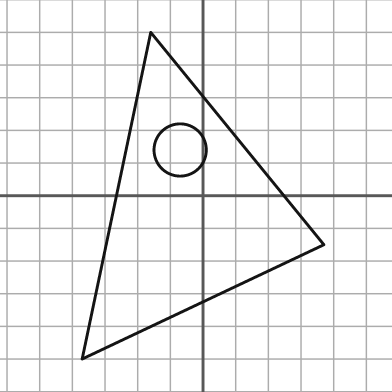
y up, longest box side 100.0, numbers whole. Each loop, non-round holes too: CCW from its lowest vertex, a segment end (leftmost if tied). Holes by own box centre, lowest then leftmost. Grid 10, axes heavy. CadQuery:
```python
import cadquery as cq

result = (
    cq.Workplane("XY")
    .moveTo(-37.0, -50.0)
    .lineTo(37.0, -15.0)
    .lineTo(-16.0, 50.0)
    .close()
    .moveTo(-7.0, 14.0)
    .circle(8.0)
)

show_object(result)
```